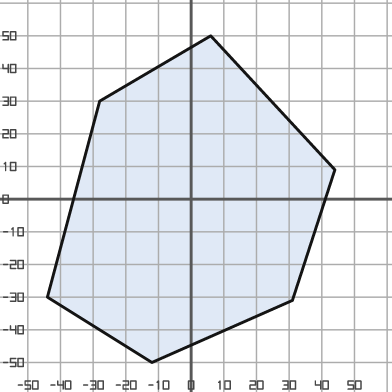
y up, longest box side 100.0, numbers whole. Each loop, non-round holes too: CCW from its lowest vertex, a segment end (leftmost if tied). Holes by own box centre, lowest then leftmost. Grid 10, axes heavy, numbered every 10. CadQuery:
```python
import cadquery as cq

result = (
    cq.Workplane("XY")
    .moveTo(-12.0, -50.0)
    .lineTo(31.0, -31.0)
    .lineTo(44.0, 9.0)
    .lineTo(6.0, 50.0)
    .lineTo(-28.0, 30.0)
    .lineTo(-44.0, -30.0)
    .close()
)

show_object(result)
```